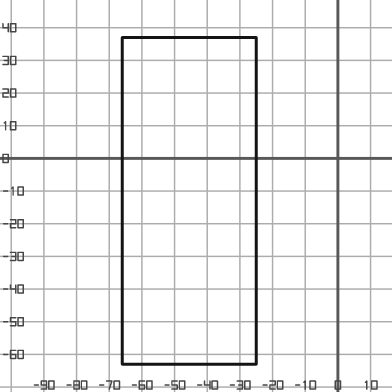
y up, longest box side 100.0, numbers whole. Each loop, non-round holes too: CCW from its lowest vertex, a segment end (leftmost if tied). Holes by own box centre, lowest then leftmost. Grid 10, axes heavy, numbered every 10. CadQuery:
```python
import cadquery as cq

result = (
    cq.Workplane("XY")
    .moveTo(-66.0, -63.0)
    .lineTo(-25.0, -63.0)
    .lineTo(-25.0, 37.0)
    .lineTo(-66.0, 37.0)
    .close()
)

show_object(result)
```